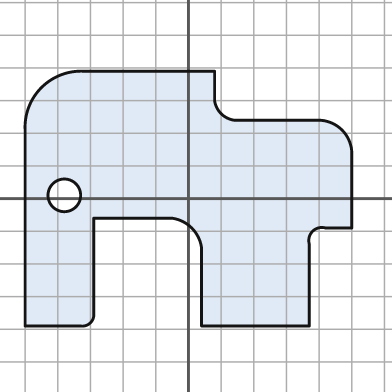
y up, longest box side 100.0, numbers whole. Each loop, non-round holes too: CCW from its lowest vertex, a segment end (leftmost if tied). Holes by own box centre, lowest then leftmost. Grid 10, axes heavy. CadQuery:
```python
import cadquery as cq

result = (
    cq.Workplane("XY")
    .moveTo(-50.0, -39.0)
    .lineTo(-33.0, -39.0)
    .threePointArc((-30.0, -38.0), (-29.0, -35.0))
    .lineTo(-29.0, -6.0)
    .lineTo(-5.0, -6.0)
    .threePointArc((1.0, -9.0), (4.0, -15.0))
    .lineTo(4.0, -39.0)
    .lineTo(37.0, -39.0)
    .lineTo(37.0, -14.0)
    .threePointArc((38.0, -10.0), (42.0, -9.0))
    .lineTo(50.0, -9.0)
    .lineTo(50.0, 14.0)
    .threePointArc((47.0, 21.0), (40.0, 24.0))
    .lineTo(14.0, 24.0)
    .threePointArc((10.0, 26.0), (8.0, 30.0))
    .lineTo(8.0, 39.0)
    .lineTo(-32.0, 39.0)
    .threePointArc((-45.0, 34.0), (-50.0, 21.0))
    .close()
    .moveTo(-38.0, 1.0)
    .circle(5.0)
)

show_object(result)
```